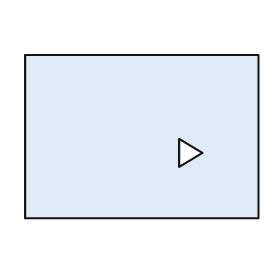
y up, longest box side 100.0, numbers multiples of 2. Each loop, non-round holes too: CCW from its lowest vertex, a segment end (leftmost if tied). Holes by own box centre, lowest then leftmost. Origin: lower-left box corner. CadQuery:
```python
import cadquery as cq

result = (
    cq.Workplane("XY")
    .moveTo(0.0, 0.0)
    .lineTo(100.0, 0.0)
    .lineTo(100.0, 70.0)
    .lineTo(0.0, 70.0)
    .close()
    .moveTo(66.0, 22.0)
    .lineTo(76.0, 28.0)
    .lineTo(66.0, 34.0)
    .close()
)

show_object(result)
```